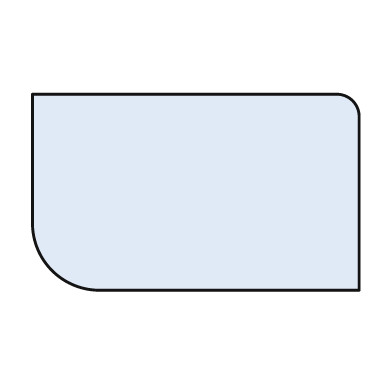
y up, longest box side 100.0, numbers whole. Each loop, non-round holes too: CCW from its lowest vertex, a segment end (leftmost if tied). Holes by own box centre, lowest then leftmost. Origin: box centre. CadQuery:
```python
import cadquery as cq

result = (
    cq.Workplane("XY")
    .moveTo(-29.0, -30.0)
    .lineTo(50.0, -30.0)
    .lineTo(50.0, 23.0)
    .threePointArc((48.0, 28.0), (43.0, 30.0))
    .lineTo(-50.0, 30.0)
    .lineTo(-50.0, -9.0)
    .threePointArc((-44.0, -24.0), (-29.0, -30.0))
    .close()
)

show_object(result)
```